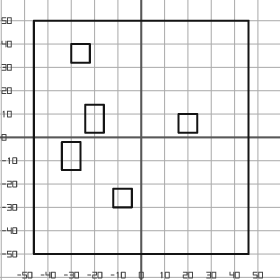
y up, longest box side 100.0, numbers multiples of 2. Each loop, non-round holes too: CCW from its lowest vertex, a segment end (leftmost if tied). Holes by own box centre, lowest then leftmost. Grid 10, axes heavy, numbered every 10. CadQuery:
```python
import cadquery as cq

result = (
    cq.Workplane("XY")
    .moveTo(-46.0, -50.0)
    .lineTo(46.0, -50.0)
    .lineTo(46.0, 50.0)
    .lineTo(-46.0, 50.0)
    .close()
    .moveTo(-12.0, -30.0)
    .lineTo(-4.0, -30.0)
    .lineTo(-4.0, -22.0)
    .lineTo(-12.0, -22.0)
    .close()
    .moveTo(-34.0, -14.0)
    .lineTo(-26.0, -14.0)
    .lineTo(-26.0, -2.0)
    .lineTo(-34.0, -2.0)
    .close()
    .moveTo(16.0, 2.0)
    .lineTo(24.0, 2.0)
    .lineTo(24.0, 10.0)
    .lineTo(16.0, 10.0)
    .close()
    .moveTo(-24.0, 2.0)
    .lineTo(-16.0, 2.0)
    .lineTo(-16.0, 14.0)
    .lineTo(-24.0, 14.0)
    .close()
    .moveTo(-30.0, 32.0)
    .lineTo(-22.0, 32.0)
    .lineTo(-22.0, 40.0)
    .lineTo(-30.0, 40.0)
    .close()
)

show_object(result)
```